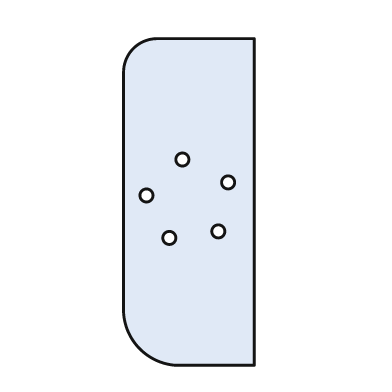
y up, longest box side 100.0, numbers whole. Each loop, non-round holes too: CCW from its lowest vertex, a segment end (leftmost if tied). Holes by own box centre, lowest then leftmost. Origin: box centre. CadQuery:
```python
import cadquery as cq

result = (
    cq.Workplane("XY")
    .moveTo(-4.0, -50.0)
    .lineTo(20.0, -50.0)
    .lineTo(20.0, 50.0)
    .lineTo(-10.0, 50.0)
    .threePointArc((-17.0, 47.0), (-20.0, 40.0))
    .lineTo(-20.0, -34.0)
    .threePointArc((-15.0, -45.0), (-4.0, -50.0))
    .close()
    .moveTo(-6.0, -11.0)
    .circle(2.0)
    .moveTo(9.0, -9.0)
    .circle(2.0)
    .moveTo(-13.0, 2.0)
    .circle(2.0)
    .moveTo(12.0, 6.0)
    .circle(2.0)
    .moveTo(-2.0, 13.0)
    .circle(2.0)
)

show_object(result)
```